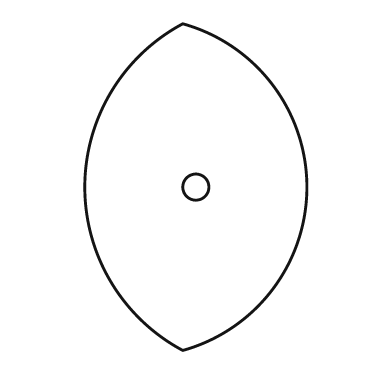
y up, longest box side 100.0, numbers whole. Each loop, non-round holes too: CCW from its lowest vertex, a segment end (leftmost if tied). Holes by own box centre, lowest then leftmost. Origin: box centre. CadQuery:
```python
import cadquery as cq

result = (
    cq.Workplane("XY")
    .moveTo(-4.0, -50.0)
    .threePointArc((34.0, 0.0), (-4.0, 50.0))
    .threePointArc((-34.0, 0.0), (-4.0, -50.0))
    .close()
    .moveTo(0.0, 0.0)
    .circle(4.0)
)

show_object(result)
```